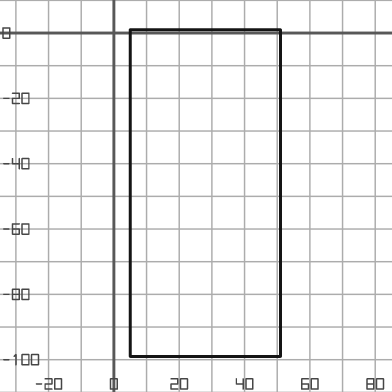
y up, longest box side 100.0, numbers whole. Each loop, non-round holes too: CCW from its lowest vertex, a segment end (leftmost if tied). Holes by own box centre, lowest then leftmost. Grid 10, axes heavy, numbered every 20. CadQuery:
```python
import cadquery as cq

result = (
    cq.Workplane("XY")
    .moveTo(5.0, -99.0)
    .lineTo(51.0, -99.0)
    .lineTo(51.0, 1.0)
    .lineTo(5.0, 1.0)
    .close()
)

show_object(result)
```